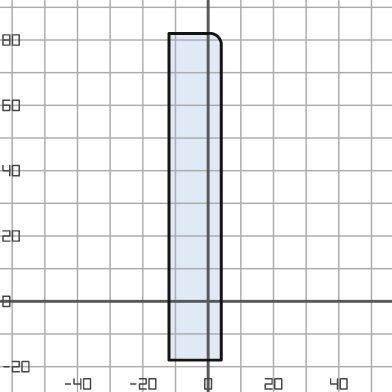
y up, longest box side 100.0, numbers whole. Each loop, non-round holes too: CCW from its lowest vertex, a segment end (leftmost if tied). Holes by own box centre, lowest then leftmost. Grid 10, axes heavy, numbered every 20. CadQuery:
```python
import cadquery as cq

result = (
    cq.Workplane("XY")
    .moveTo(-12.0, -18.0)
    .lineTo(4.0, -18.0)
    .lineTo(4.0, 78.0)
    .threePointArc((3.0, 81.0), (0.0, 82.0))
    .lineTo(-12.0, 82.0)
    .close()
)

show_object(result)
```